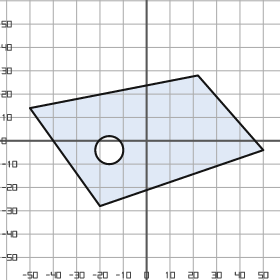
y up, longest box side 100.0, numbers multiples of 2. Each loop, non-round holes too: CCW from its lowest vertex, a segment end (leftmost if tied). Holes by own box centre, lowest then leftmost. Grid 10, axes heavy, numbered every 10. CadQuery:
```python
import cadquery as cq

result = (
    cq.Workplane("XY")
    .moveTo(-20.0, -28.0)
    .lineTo(50.0, -4.0)
    .lineTo(22.0, 28.0)
    .lineTo(-50.0, 14.0)
    .close()
    .moveTo(-16.0, -4.0)
    .circle(6.0)
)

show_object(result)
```